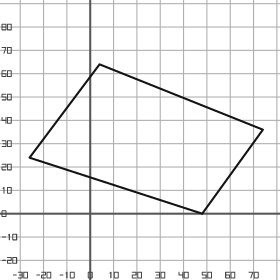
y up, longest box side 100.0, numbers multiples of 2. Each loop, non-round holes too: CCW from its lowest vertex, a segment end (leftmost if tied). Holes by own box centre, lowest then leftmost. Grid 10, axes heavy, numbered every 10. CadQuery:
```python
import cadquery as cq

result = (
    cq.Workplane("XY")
    .moveTo(48.0, 0.0)
    .lineTo(74.0, 36.0)
    .lineTo(4.0, 64.0)
    .lineTo(-26.0, 24.0)
    .close()
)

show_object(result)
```